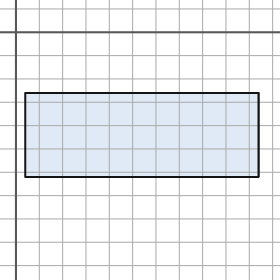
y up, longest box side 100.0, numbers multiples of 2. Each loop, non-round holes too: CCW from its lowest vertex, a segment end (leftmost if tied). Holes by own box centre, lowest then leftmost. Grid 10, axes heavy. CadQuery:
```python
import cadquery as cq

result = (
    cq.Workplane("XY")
    .moveTo(4.0, -62.0)
    .lineTo(104.0, -62.0)
    .lineTo(104.0, -26.0)
    .lineTo(4.0, -26.0)
    .close()
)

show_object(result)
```